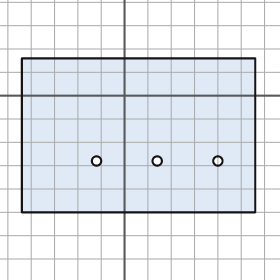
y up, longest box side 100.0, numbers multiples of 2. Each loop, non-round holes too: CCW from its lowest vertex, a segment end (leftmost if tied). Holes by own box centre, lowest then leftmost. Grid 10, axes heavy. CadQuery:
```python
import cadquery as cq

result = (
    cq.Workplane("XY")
    .moveTo(-44.0, -50.0)
    .lineTo(56.0, -50.0)
    .lineTo(56.0, 16.0)
    .lineTo(-44.0, 16.0)
    .close()
    .moveTo(-12.0, -28.0)
    .circle(2.0)
    .moveTo(14.0, -28.0)
    .circle(2.0)
    .moveTo(40.0, -28.0)
    .circle(2.0)
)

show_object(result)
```